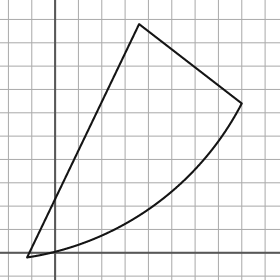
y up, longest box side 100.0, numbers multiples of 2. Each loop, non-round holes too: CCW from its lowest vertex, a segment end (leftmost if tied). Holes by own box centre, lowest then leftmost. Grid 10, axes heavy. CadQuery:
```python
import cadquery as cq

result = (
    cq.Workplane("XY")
    .moveTo(-12.0, -2.0)
    .threePointArc((42.0, 20.0), (80.0, 64.0))
    .lineTo(36.0, 98.0)
    .close()
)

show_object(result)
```